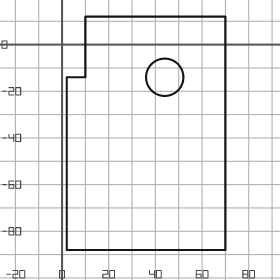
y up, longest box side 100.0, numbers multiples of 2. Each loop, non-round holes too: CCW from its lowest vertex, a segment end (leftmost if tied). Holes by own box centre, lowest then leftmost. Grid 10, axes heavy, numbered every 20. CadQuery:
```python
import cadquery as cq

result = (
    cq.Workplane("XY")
    .moveTo(2.0, -88.0)
    .lineTo(70.0, -88.0)
    .lineTo(70.0, 12.0)
    .lineTo(10.0, 12.0)
    .lineTo(10.0, -14.0)
    .lineTo(2.0, -14.0)
    .close()
    .moveTo(44.0, -14.0)
    .circle(8.0)
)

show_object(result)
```